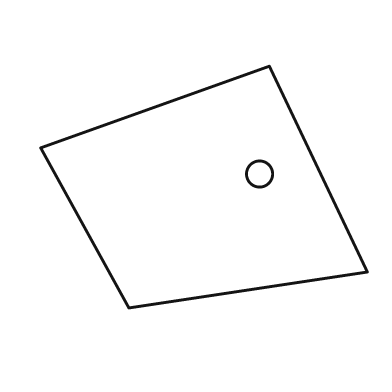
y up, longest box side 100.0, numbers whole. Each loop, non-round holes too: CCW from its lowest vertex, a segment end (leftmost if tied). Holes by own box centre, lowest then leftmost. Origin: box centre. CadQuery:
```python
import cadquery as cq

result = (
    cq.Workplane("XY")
    .moveTo(-23.0, -37.0)
    .lineTo(50.0, -26.0)
    .lineTo(20.0, 37.0)
    .lineTo(-50.0, 12.0)
    .close()
    .moveTo(17.0, 4.0)
    .circle(4.0)
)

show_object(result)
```